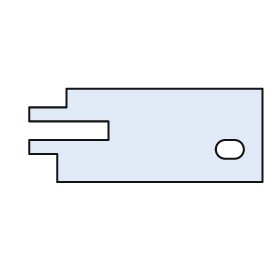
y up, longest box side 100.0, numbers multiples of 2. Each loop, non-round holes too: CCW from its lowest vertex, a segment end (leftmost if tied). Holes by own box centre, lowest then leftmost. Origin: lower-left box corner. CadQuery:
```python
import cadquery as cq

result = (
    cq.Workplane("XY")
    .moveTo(12.0, 0.0)
    .lineTo(100.0, 0.0)
    .lineTo(100.0, 40.0)
    .lineTo(16.0, 40.0)
    .lineTo(16.0, 32.0)
    .lineTo(0.0, 32.0)
    .lineTo(0.0, 26.0)
    .lineTo(34.0, 26.0)
    .lineTo(34.0, 18.0)
    .lineTo(0.0, 18.0)
    .lineTo(0.0, 12.0)
    .lineTo(12.0, 12.0)
    .close()
    .moveTo(84.0, 10.0)
    .lineTo(88.0, 10.0)
    .threePointArc((92.0, 14.0), (88.0, 18.0))
    .lineTo(84.0, 18.0)
    .threePointArc((80.0, 14.0), (84.0, 10.0))
    .close()
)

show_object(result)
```